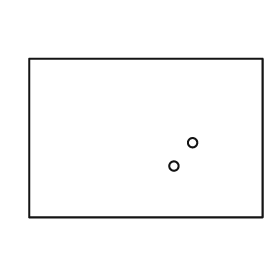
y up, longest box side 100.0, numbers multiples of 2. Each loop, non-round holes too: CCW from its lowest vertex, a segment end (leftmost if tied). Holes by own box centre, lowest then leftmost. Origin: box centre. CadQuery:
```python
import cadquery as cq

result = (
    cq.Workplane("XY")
    .moveTo(-50.0, -34.0)
    .lineTo(50.0, -34.0)
    .lineTo(50.0, 34.0)
    .lineTo(-50.0, 34.0)
    .close()
    .moveTo(12.0, -12.0)
    .circle(2.0)
    .moveTo(20.0, -2.0)
    .circle(2.0)
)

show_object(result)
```